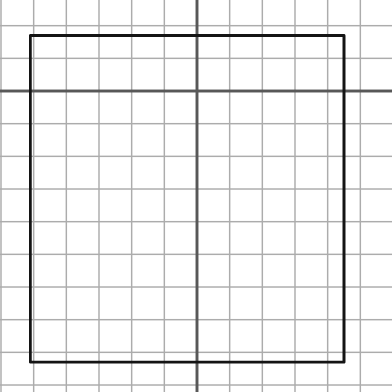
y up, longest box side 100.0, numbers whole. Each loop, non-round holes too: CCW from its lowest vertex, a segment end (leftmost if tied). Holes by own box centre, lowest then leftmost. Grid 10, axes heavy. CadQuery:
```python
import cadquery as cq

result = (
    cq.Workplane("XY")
    .moveTo(-51.0, -83.0)
    .lineTo(45.0, -83.0)
    .lineTo(45.0, 17.0)
    .lineTo(-51.0, 17.0)
    .close()
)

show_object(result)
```